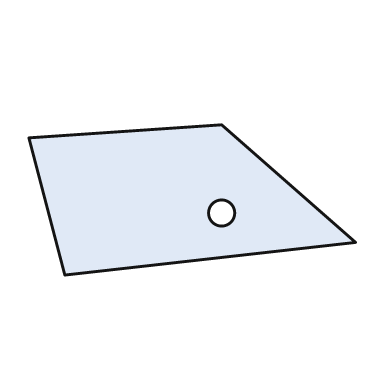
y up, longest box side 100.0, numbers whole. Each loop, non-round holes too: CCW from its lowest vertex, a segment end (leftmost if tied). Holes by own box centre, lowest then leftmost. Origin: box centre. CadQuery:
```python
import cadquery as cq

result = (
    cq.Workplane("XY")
    .moveTo(-39.0, -23.0)
    .lineTo(50.0, -13.0)
    .lineTo(9.0, 23.0)
    .lineTo(-50.0, 19.0)
    .close()
    .moveTo(9.0, -4.0)
    .circle(4.0)
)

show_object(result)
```